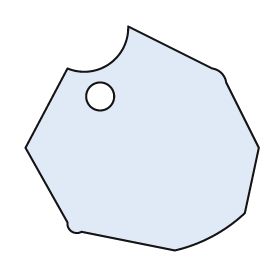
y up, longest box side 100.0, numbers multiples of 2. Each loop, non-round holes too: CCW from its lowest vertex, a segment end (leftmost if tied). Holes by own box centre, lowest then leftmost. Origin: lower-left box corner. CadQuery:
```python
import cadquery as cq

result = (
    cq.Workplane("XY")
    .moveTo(64.0, 0.0)
    .threePointArc((80.0, 6.0), (94.0, 16.0))
    .lineTo(100.0, 44.0)
    .lineTo(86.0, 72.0)
    .threePointArc((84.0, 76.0), (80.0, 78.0))
    .lineTo(44.0, 96.0)
    .threePointArc((36.0, 80.0), (18.0, 78.0))
    .lineTo(0.0, 44.0)
    .lineTo(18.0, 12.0)
    .threePointArc((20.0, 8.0), (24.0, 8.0))
    .close()
    .moveTo(32.0, 66.0)
    .circle(6.0)
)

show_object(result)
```